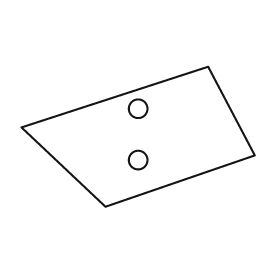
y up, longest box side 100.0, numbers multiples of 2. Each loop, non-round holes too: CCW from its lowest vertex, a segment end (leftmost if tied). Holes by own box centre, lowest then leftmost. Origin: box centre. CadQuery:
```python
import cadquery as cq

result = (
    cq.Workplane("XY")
    .moveTo(-14.0, -30.0)
    .lineTo(50.0, -8.0)
    .lineTo(30.0, 30.0)
    .lineTo(-50.0, 4.0)
    .close()
    .moveTo(0.0, -10.0)
    .circle(4.0)
    .moveTo(0.0, 12.0)
    .circle(4.0)
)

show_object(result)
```